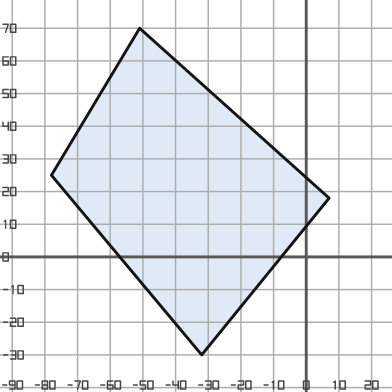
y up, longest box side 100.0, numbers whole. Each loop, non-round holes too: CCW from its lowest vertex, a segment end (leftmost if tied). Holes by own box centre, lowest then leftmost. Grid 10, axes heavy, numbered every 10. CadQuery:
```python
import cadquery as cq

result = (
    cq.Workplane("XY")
    .moveTo(-32.0, -30.0)
    .lineTo(7.0, 18.0)
    .lineTo(-51.0, 70.0)
    .lineTo(-78.0, 25.0)
    .close()
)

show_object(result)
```